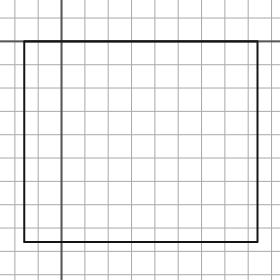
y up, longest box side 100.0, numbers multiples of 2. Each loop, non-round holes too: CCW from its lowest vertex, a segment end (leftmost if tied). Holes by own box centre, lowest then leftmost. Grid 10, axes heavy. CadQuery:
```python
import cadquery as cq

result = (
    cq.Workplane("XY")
    .moveTo(-16.0, -86.0)
    .lineTo(84.0, -86.0)
    .lineTo(84.0, 0.0)
    .lineTo(-16.0, 0.0)
    .close()
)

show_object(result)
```